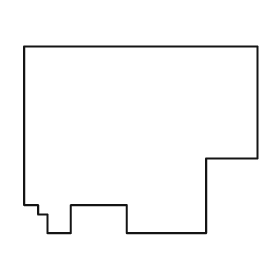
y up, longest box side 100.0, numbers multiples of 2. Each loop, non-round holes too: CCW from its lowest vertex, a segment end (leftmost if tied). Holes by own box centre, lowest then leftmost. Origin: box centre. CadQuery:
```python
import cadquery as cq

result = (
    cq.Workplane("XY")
    .moveTo(-40.0, -40.0)
    .lineTo(-30.0, -40.0)
    .lineTo(-30.0, -28.0)
    .lineTo(-6.0, -28.0)
    .lineTo(-6.0, -40.0)
    .lineTo(28.0, -40.0)
    .lineTo(28.0, -8.0)
    .lineTo(50.0, -8.0)
    .lineTo(50.0, 40.0)
    .lineTo(-50.0, 40.0)
    .lineTo(-50.0, -28.0)
    .lineTo(-44.0, -28.0)
    .lineTo(-44.0, -32.0)
    .lineTo(-40.0, -32.0)
    .close()
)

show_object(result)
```